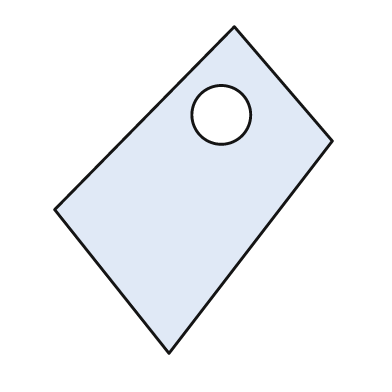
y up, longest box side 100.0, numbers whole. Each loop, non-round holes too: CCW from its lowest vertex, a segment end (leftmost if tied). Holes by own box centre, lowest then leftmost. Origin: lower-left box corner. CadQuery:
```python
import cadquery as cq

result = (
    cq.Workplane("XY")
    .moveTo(35.0, 0.0)
    .lineTo(85.0, 65.0)
    .lineTo(55.0, 100.0)
    .lineTo(0.0, 44.0)
    .close()
    .moveTo(51.0, 73.0)
    .circle(9.0)
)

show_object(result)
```